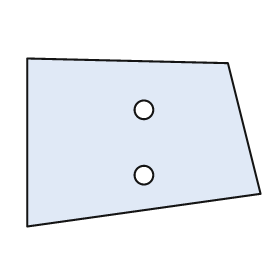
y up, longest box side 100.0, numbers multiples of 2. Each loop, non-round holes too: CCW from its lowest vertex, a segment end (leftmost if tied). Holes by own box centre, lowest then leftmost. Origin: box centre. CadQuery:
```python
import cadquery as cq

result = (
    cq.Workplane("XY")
    .moveTo(-50.0, -36.0)
    .lineTo(50.0, -22.0)
    .lineTo(36.0, 34.0)
    .lineTo(-50.0, 36.0)
    .close()
    .moveTo(0.0, -14.0)
    .circle(4.0)
    .moveTo(0.0, 14.0)
    .circle(4.0)
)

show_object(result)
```